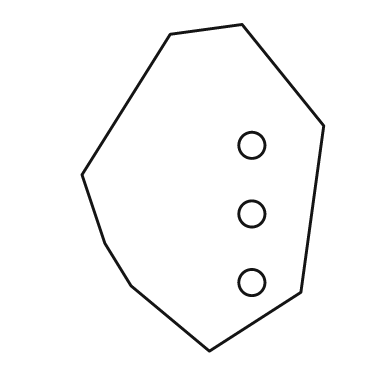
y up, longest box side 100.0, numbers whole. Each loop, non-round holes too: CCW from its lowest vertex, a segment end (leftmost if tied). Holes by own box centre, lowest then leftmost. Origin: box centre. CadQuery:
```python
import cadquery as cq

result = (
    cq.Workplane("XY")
    .moveTo(2.0, -50.0)
    .lineTo(30.0, -32.0)
    .lineTo(37.0, 19.0)
    .lineTo(12.0, 50.0)
    .lineTo(-10.0, 47.0)
    .lineTo(-37.0, 4.0)
    .lineTo(-30.0, -17.0)
    .lineTo(-22.0, -30.0)
    .close()
    .moveTo(15.0, -29.0)
    .circle(4.0)
    .moveTo(15.0, -8.0)
    .circle(4.0)
    .moveTo(15.0, 13.0)
    .circle(4.0)
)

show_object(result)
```